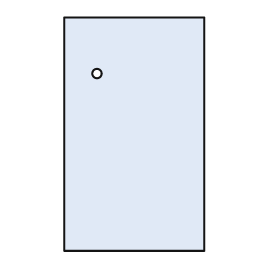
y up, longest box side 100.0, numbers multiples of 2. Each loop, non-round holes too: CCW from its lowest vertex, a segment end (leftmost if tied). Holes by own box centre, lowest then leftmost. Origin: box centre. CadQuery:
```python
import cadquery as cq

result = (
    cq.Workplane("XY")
    .moveTo(-30.0, -50.0)
    .lineTo(30.0, -50.0)
    .lineTo(30.0, 50.0)
    .lineTo(-30.0, 50.0)
    .close()
    .moveTo(-16.0, 26.0)
    .circle(2.0)
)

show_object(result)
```